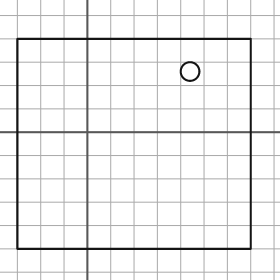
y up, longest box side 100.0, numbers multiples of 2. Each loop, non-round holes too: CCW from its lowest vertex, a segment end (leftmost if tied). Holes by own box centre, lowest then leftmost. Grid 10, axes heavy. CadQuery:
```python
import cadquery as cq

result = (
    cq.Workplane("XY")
    .moveTo(-30.0, -50.0)
    .lineTo(70.0, -50.0)
    .lineTo(70.0, 40.0)
    .lineTo(-30.0, 40.0)
    .close()
    .moveTo(44.0, 26.0)
    .circle(4.0)
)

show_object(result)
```